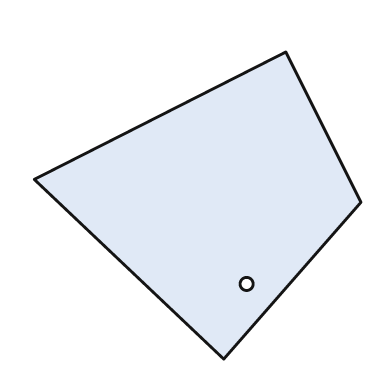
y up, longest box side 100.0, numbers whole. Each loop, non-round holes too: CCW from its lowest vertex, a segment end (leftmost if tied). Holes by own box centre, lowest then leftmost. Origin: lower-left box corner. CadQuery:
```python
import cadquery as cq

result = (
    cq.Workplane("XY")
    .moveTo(58.0, 0.0)
    .lineTo(100.0, 48.0)
    .lineTo(77.0, 94.0)
    .lineTo(0.0, 55.0)
    .close()
    .moveTo(65.0, 23.0)
    .circle(2.0)
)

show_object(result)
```